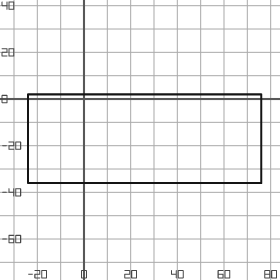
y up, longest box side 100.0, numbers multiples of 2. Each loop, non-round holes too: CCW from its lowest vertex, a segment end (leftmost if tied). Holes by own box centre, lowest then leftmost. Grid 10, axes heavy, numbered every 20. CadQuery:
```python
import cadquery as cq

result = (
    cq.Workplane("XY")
    .moveTo(-24.0, -36.0)
    .lineTo(76.0, -36.0)
    .lineTo(76.0, 2.0)
    .lineTo(-24.0, 2.0)
    .close()
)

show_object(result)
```